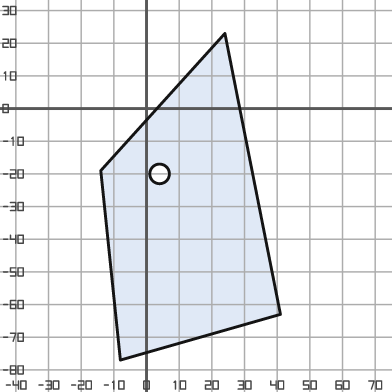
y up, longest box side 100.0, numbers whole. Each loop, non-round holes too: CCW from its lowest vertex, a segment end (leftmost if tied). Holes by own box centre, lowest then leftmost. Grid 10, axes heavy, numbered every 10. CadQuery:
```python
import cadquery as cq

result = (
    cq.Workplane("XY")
    .moveTo(-8.0, -77.0)
    .lineTo(41.0, -63.0)
    .lineTo(24.0, 23.0)
    .lineTo(-14.0, -19.0)
    .close()
    .moveTo(4.0, -20.0)
    .circle(3.0)
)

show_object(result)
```